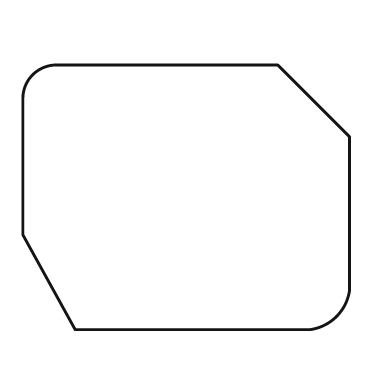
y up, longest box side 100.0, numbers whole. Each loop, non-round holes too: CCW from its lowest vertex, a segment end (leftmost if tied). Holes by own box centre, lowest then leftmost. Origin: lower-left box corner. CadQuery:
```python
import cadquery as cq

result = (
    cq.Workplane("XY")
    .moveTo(16.0, 0.0)
    .lineTo(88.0, 0.0)
    .threePointArc((96.0, 4.0), (100.0, 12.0))
    .lineTo(100.0, 59.0)
    .lineTo(78.0, 81.0)
    .lineTo(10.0, 81.0)
    .threePointArc((3.0, 78.0), (0.0, 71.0))
    .lineTo(0.0, 29.0)
    .close()
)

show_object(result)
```